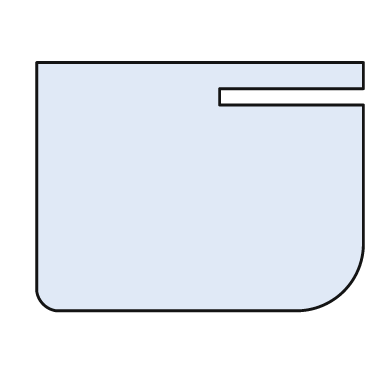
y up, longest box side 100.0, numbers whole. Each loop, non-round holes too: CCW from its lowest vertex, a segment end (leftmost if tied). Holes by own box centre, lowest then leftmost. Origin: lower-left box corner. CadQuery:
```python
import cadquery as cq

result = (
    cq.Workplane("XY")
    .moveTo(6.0, 0.0)
    .lineTo(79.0, 0.0)
    .threePointArc((94.0, 6.0), (100.0, 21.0))
    .lineTo(100.0, 63.0)
    .lineTo(56.0, 63.0)
    .lineTo(56.0, 68.0)
    .lineTo(100.0, 68.0)
    .lineTo(100.0, 76.0)
    .lineTo(0.0, 76.0)
    .lineTo(0.0, 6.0)
    .threePointArc((2.0, 2.0), (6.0, 0.0))
    .close()
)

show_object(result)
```